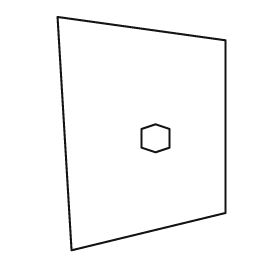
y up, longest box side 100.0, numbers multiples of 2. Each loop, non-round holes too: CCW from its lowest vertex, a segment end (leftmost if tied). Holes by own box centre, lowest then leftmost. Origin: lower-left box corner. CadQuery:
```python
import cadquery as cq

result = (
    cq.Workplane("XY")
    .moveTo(6.0, 0.0)
    .lineTo(72.0, 16.0)
    .lineTo(72.0, 90.0)
    .lineTo(0.0, 100.0)
    .close()
    .moveTo(42.0, 42.0)
    .lineTo(48.0, 44.0)
    .lineTo(48.0, 52.0)
    .lineTo(42.0, 54.0)
    .lineTo(36.0, 52.0)
    .lineTo(36.0, 44.0)
    .close()
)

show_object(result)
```